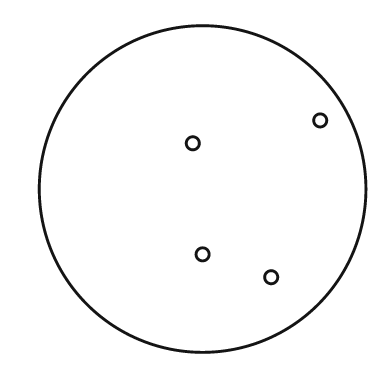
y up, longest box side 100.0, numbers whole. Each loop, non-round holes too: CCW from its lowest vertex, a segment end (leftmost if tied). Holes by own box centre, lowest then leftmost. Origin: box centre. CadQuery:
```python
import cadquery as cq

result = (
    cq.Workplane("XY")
    .moveTo(0.0, 0.0)
    .circle(50.0)
    .moveTo(21.0, -27.0)
    .circle(2.0)
    .moveTo(0.0, -20.0)
    .circle(2.0)
    .moveTo(-3.0, 14.0)
    .circle(2.0)
    .moveTo(36.0, 21.0)
    .circle(2.0)
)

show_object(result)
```